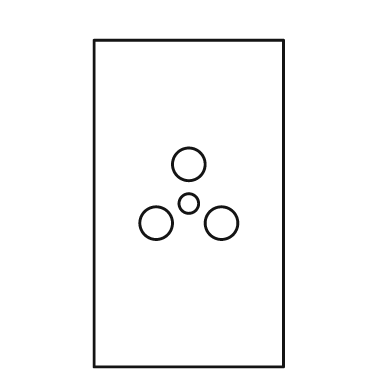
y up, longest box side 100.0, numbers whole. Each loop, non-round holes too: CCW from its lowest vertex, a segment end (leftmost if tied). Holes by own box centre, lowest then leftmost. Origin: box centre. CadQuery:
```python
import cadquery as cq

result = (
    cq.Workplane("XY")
    .moveTo(-29.0, -50.0)
    .lineTo(29.0, -50.0)
    .lineTo(29.0, 50.0)
    .lineTo(-29.0, 50.0)
    .close()
    .moveTo(-10.0, -6.0)
    .circle(5.0)
    .moveTo(10.0, -6.0)
    .circle(5.0)
    .moveTo(0.0, 0.0)
    .circle(3.0)
    .moveTo(0.0, 12.0)
    .circle(5.0)
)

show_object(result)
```